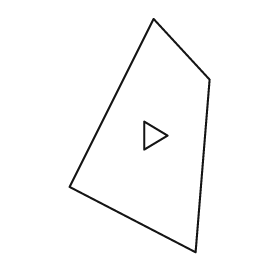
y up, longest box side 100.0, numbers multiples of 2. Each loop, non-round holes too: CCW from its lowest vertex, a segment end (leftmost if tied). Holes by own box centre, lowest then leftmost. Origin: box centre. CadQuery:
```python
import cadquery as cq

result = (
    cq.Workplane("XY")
    .moveTo(24.0, -50.0)
    .lineTo(30.0, 24.0)
    .lineTo(6.0, 50.0)
    .lineTo(-30.0, -22.0)
    .close()
    .moveTo(2.0, -6.0)
    .lineTo(12.0, 0.0)
    .lineTo(2.0, 6.0)
    .close()
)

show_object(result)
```